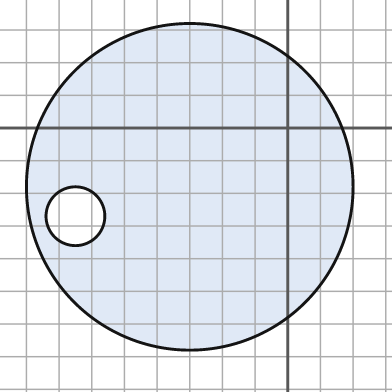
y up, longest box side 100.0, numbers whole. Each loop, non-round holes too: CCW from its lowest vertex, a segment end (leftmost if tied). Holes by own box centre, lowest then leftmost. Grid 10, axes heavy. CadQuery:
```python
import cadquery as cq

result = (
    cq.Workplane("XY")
    .moveTo(-30.0, -18.0)
    .circle(50.0)
    .moveTo(-65.0, -27.0)
    .circle(9.0)
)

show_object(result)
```